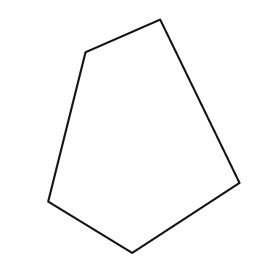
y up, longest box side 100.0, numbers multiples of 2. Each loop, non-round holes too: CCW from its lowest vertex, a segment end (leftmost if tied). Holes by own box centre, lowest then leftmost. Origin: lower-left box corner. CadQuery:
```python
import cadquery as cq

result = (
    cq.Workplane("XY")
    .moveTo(36.0, 0.0)
    .lineTo(82.0, 30.0)
    .lineTo(48.0, 100.0)
    .lineTo(16.0, 86.0)
    .lineTo(0.0, 22.0)
    .close()
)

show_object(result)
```